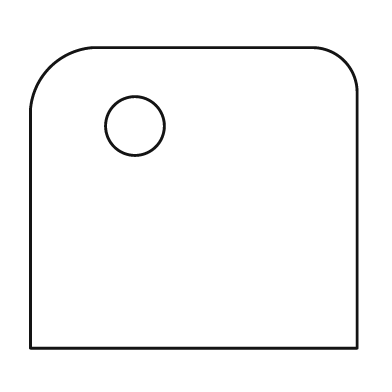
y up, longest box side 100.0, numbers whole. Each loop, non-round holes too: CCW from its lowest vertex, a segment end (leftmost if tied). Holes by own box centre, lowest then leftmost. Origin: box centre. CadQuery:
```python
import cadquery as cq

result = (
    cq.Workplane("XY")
    .moveTo(-50.0, -46.0)
    .lineTo(50.0, -46.0)
    .lineTo(50.0, 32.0)
    .threePointArc((46.0, 42.0), (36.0, 46.0))
    .lineTo(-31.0, 46.0)
    .threePointArc((-44.0, 40.0), (-50.0, 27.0))
    .close()
    .moveTo(-18.0, 22.0)
    .circle(9.0)
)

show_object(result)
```